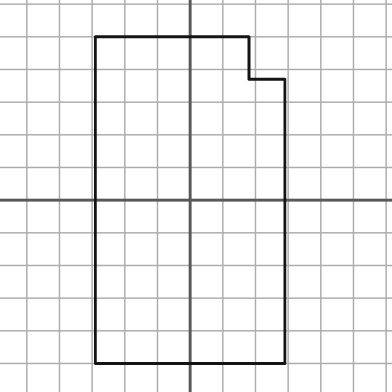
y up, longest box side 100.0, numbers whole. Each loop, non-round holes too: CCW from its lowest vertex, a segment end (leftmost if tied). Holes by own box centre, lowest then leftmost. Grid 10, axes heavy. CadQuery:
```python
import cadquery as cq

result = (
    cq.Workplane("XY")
    .moveTo(-29.0, -50.0)
    .lineTo(29.0, -50.0)
    .lineTo(29.0, 37.0)
    .lineTo(18.0, 37.0)
    .lineTo(18.0, 50.0)
    .lineTo(-29.0, 50.0)
    .close()
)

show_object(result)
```